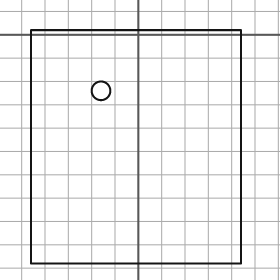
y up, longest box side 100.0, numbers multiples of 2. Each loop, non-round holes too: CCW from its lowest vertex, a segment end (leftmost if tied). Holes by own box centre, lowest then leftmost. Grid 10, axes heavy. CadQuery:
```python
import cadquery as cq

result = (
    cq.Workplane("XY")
    .moveTo(-46.0, -98.0)
    .lineTo(44.0, -98.0)
    .lineTo(44.0, 2.0)
    .lineTo(-46.0, 2.0)
    .close()
    .moveTo(-16.0, -24.0)
    .circle(4.0)
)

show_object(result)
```